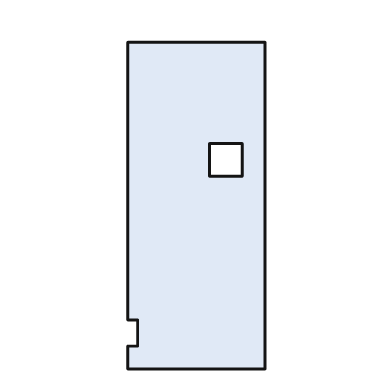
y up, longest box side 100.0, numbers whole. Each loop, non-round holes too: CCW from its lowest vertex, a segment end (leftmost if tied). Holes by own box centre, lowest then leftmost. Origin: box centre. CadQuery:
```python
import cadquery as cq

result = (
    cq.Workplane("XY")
    .moveTo(-21.0, -50.0)
    .lineTo(21.0, -50.0)
    .lineTo(21.0, 50.0)
    .lineTo(-21.0, 50.0)
    .lineTo(-21.0, -35.0)
    .lineTo(-18.0, -35.0)
    .lineTo(-18.0, -43.0)
    .lineTo(-21.0, -43.0)
    .close()
    .moveTo(4.0, 9.0)
    .lineTo(14.0, 9.0)
    .lineTo(14.0, 19.0)
    .lineTo(4.0, 19.0)
    .close()
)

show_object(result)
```